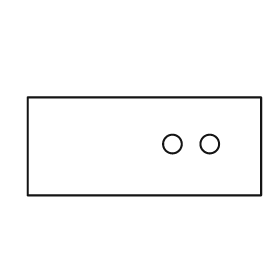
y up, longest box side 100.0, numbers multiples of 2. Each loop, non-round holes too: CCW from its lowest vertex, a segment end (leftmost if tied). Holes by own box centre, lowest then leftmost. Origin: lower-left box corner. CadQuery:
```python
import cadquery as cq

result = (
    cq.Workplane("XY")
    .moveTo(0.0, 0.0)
    .lineTo(100.0, 0.0)
    .lineTo(100.0, 42.0)
    .lineTo(0.0, 42.0)
    .close()
    .moveTo(62.0, 22.0)
    .circle(4.0)
    .moveTo(78.0, 22.0)
    .circle(4.0)
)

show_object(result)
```